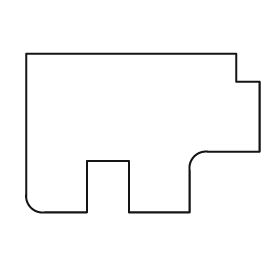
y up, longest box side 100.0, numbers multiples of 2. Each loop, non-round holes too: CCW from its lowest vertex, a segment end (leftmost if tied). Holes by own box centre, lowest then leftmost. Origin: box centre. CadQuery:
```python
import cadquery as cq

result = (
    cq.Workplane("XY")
    .moveTo(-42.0, -34.0)
    .lineTo(-24.0, -34.0)
    .lineTo(-24.0, -12.0)
    .lineTo(-6.0, -12.0)
    .lineTo(-6.0, -34.0)
    .lineTo(20.0, -34.0)
    .lineTo(20.0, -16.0)
    .threePointArc((22.0, -10.0), (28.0, -8.0))
    .lineTo(50.0, -8.0)
    .lineTo(50.0, 22.0)
    .lineTo(40.0, 22.0)
    .lineTo(40.0, 34.0)
    .lineTo(-50.0, 34.0)
    .lineTo(-50.0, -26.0)
    .threePointArc((-48.0, -32.0), (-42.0, -34.0))
    .close()
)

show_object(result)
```